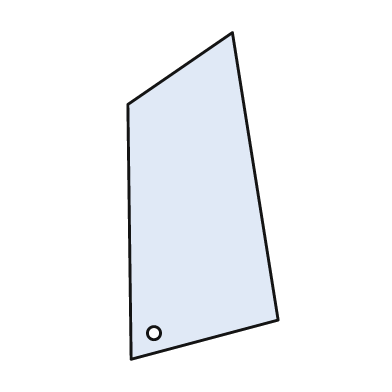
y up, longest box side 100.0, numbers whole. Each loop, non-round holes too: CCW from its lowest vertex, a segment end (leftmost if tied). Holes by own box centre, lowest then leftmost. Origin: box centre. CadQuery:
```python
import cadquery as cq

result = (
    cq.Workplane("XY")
    .moveTo(-22.0, -50.0)
    .lineTo(23.0, -38.0)
    .lineTo(9.0, 50.0)
    .lineTo(-23.0, 28.0)
    .close()
    .moveTo(-15.0, -42.0)
    .circle(2.0)
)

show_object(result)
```